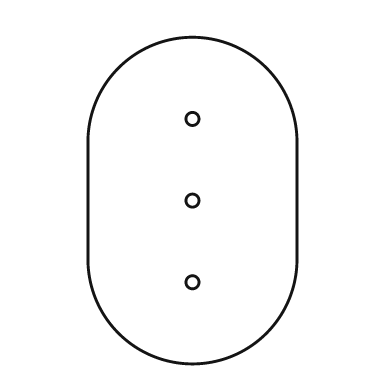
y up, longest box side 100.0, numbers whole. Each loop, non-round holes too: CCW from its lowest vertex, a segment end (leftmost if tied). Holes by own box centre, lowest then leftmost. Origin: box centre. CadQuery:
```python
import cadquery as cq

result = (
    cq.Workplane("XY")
    .moveTo(-32.0, -18.0)
    .threePointArc((0.0, -50.0), (32.0, -18.0))
    .lineTo(32.0, 18.0)
    .threePointArc((0.0, 50.0), (-32.0, 18.0))
    .close()
    .moveTo(0.0, -25.0)
    .circle(2.0)
    .moveTo(0.0, 0.0)
    .circle(2.0)
    .moveTo(0.0, 25.0)
    .circle(2.0)
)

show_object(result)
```